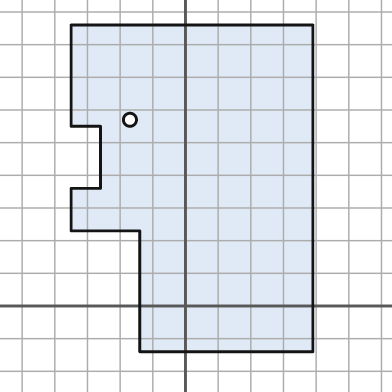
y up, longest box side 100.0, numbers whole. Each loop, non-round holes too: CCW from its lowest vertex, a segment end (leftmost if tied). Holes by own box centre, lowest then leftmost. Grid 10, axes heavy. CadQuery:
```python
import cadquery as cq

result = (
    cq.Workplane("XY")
    .moveTo(-14.0, -14.0)
    .lineTo(39.0, -14.0)
    .lineTo(39.0, 86.0)
    .lineTo(-35.0, 86.0)
    .lineTo(-35.0, 55.0)
    .lineTo(-26.0, 55.0)
    .lineTo(-26.0, 36.0)
    .lineTo(-35.0, 36.0)
    .lineTo(-35.0, 23.0)
    .lineTo(-14.0, 23.0)
    .close()
    .moveTo(-17.0, 57.0)
    .circle(2.0)
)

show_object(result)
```